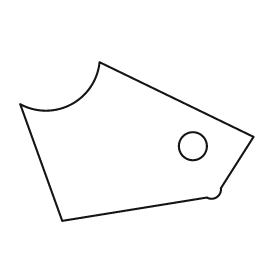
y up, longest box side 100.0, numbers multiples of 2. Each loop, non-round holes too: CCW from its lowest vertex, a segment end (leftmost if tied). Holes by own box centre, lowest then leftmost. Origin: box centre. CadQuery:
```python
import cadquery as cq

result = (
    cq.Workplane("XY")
    .moveTo(-32.0, -34.0)
    .lineTo(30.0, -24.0)
    .threePointArc((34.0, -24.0), (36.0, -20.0))
    .lineTo(50.0, 2.0)
    .lineTo(-16.0, 34.0)
    .threePointArc((-28.0, 16.0), (-50.0, 16.0))
    .close()
    .moveTo(24.0, -2.0)
    .circle(6.0)
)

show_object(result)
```